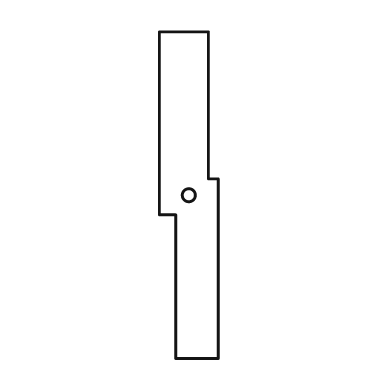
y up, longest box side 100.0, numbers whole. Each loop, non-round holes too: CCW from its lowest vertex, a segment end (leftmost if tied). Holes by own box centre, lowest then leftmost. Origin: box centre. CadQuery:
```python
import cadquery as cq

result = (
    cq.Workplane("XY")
    .moveTo(-4.0, -50.0)
    .lineTo(9.0, -50.0)
    .lineTo(9.0, 5.0)
    .lineTo(6.0, 5.0)
    .lineTo(6.0, 50.0)
    .lineTo(-9.0, 50.0)
    .lineTo(-9.0, -6.0)
    .lineTo(-4.0, -6.0)
    .close()
    .moveTo(0.0, 0.0)
    .circle(2.0)
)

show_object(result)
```